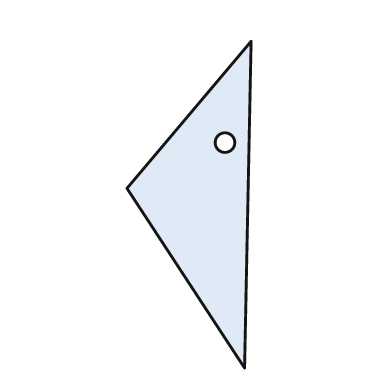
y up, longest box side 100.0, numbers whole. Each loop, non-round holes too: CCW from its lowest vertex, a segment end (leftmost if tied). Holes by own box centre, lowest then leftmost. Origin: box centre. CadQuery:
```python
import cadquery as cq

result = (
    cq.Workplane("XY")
    .moveTo(17.0, -50.0)
    .lineTo(19.0, 50.0)
    .lineTo(-19.0, 5.0)
    .close()
    .moveTo(11.0, 19.0)
    .circle(3.0)
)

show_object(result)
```